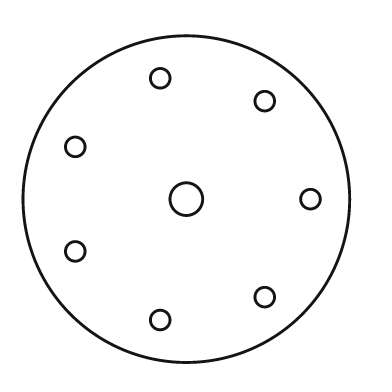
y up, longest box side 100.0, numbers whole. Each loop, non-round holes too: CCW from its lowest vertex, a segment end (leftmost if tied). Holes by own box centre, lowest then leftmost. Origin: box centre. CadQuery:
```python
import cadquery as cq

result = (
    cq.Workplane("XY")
    .moveTo(0.0, 0.0)
    .circle(50.0)
    .moveTo(-8.0, -37.0)
    .circle(3.0)
    .moveTo(24.0, -30.0)
    .circle(3.0)
    .moveTo(-34.0, -16.0)
    .circle(3.0)
    .moveTo(0.0, 0.0)
    .circle(5.0)
    .moveTo(38.0, 0.0)
    .circle(3.0)
    .moveTo(-34.0, 16.0)
    .circle(3.0)
    .moveTo(24.0, 30.0)
    .circle(3.0)
    .moveTo(-8.0, 37.0)
    .circle(3.0)
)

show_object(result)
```